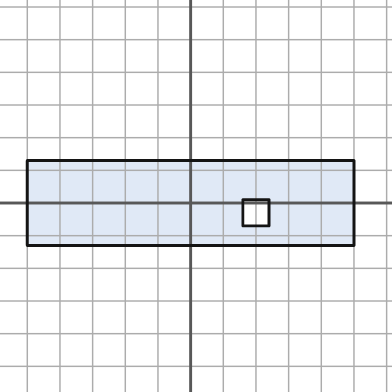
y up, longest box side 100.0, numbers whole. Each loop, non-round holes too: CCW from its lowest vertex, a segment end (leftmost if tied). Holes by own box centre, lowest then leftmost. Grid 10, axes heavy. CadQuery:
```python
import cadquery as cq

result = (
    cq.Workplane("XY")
    .moveTo(-50.0, -13.0)
    .lineTo(50.0, -13.0)
    .lineTo(50.0, 13.0)
    .lineTo(-50.0, 13.0)
    .close()
    .moveTo(16.0, -7.0)
    .lineTo(24.0, -7.0)
    .lineTo(24.0, 1.0)
    .lineTo(16.0, 1.0)
    .close()
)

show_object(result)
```